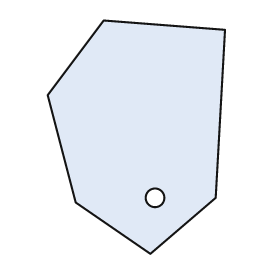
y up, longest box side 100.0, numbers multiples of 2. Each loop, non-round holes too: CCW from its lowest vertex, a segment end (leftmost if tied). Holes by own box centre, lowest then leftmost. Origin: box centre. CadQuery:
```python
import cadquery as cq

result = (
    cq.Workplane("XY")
    .moveTo(6.0, -50.0)
    .lineTo(34.0, -26.0)
    .lineTo(38.0, 46.0)
    .lineTo(-14.0, 50.0)
    .lineTo(-38.0, 18.0)
    .lineTo(-26.0, -28.0)
    .close()
    .moveTo(8.0, -26.0)
    .circle(4.0)
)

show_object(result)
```